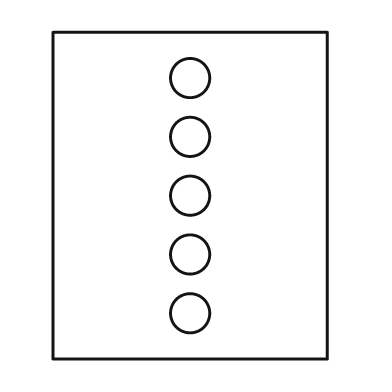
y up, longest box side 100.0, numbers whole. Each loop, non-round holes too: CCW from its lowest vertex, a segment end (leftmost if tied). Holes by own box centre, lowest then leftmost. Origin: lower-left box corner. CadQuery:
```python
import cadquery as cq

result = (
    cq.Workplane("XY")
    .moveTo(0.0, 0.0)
    .lineTo(84.0, 0.0)
    .lineTo(84.0, 100.0)
    .lineTo(0.0, 100.0)
    .close()
    .moveTo(42.0, 14.0)
    .circle(6.0)
    .moveTo(42.0, 32.0)
    .circle(6.0)
    .moveTo(42.0, 50.0)
    .circle(6.0)
    .moveTo(42.0, 68.0)
    .circle(6.0)
    .moveTo(42.0, 86.0)
    .circle(6.0)
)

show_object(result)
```